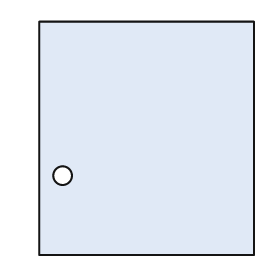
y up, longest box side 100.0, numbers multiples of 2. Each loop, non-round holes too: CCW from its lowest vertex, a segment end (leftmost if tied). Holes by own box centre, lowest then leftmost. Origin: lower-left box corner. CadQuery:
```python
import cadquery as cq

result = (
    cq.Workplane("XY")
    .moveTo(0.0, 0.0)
    .lineTo(92.0, 0.0)
    .lineTo(92.0, 100.0)
    .lineTo(0.0, 100.0)
    .close()
    .moveTo(10.0, 34.0)
    .circle(4.0)
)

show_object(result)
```